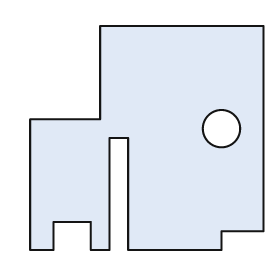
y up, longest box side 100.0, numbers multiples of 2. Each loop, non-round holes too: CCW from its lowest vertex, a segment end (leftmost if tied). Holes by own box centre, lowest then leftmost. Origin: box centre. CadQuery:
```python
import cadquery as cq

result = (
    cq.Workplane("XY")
    .moveTo(-50.0, -48.0)
    .lineTo(-40.0, -48.0)
    .lineTo(-40.0, -36.0)
    .lineTo(-24.0, -36.0)
    .lineTo(-24.0, -48.0)
    .lineTo(-16.0, -48.0)
    .lineTo(-16.0, 0.0)
    .lineTo(-8.0, 0.0)
    .lineTo(-8.0, -48.0)
    .lineTo(32.0, -48.0)
    .lineTo(32.0, -40.0)
    .lineTo(50.0, -40.0)
    .lineTo(50.0, 48.0)
    .lineTo(-20.0, 48.0)
    .lineTo(-20.0, 8.0)
    .lineTo(-50.0, 8.0)
    .close()
    .moveTo(32.0, 4.0)
    .circle(8.0)
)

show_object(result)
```